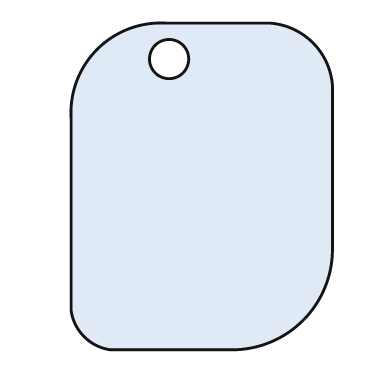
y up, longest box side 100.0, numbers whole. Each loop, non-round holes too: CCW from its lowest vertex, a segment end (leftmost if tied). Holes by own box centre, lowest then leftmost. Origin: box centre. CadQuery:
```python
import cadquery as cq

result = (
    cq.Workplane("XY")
    .moveTo(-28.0, -50.0)
    .lineTo(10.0, -50.0)
    .threePointArc((31.0, -41.0), (40.0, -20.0))
    .lineTo(40.0, 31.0)
    .threePointArc((34.0, 44.0), (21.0, 50.0))
    .lineTo(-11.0, 50.0)
    .threePointArc((-32.0, 42.0), (-40.0, 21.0))
    .lineTo(-40.0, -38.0)
    .threePointArc((-36.0, -46.0), (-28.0, -50.0))
    .close()
    .moveTo(-10.0, 39.0)
    .circle(6.0)
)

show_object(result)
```